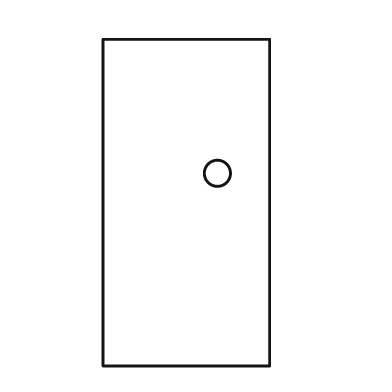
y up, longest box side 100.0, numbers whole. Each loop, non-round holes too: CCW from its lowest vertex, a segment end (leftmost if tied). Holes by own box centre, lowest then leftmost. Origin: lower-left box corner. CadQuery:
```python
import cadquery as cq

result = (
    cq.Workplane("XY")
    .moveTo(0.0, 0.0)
    .lineTo(51.0, 0.0)
    .lineTo(51.0, 100.0)
    .lineTo(0.0, 100.0)
    .close()
    .moveTo(35.0, 59.0)
    .circle(4.0)
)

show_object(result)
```